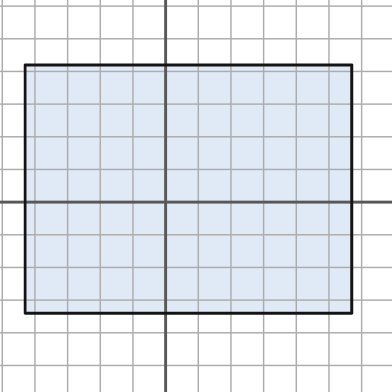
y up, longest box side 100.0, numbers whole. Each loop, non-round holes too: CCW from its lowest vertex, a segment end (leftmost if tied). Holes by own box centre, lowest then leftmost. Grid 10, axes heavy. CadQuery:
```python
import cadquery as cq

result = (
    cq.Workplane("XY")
    .moveTo(-43.0, -34.0)
    .lineTo(57.0, -34.0)
    .lineTo(57.0, 42.0)
    .lineTo(-43.0, 42.0)
    .close()
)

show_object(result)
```